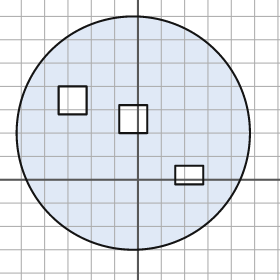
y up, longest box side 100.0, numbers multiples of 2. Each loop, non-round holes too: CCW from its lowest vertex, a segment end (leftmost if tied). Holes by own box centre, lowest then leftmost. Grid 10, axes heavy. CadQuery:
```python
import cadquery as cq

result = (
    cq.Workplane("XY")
    .moveTo(-2.0, 20.0)
    .circle(50.0)
    .moveTo(16.0, -2.0)
    .lineTo(28.0, -2.0)
    .lineTo(28.0, 6.0)
    .lineTo(16.0, 6.0)
    .close()
    .moveTo(-8.0, 20.0)
    .lineTo(4.0, 20.0)
    .lineTo(4.0, 32.0)
    .lineTo(-8.0, 32.0)
    .close()
    .moveTo(-34.0, 28.0)
    .lineTo(-22.0, 28.0)
    .lineTo(-22.0, 40.0)
    .lineTo(-34.0, 40.0)
    .close()
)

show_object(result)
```